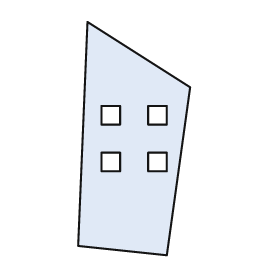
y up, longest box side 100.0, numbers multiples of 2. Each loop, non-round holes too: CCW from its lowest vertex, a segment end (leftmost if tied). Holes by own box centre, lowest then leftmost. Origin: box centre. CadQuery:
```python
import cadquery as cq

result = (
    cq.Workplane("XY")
    .moveTo(14.0, -50.0)
    .lineTo(24.0, 22.0)
    .lineTo(-20.0, 50.0)
    .lineTo(-24.0, -46.0)
    .close()
    .moveTo(-14.0, -14.0)
    .lineTo(-6.0, -14.0)
    .lineTo(-6.0, -6.0)
    .lineTo(-14.0, -6.0)
    .close()
    .moveTo(6.0, -14.0)
    .lineTo(14.0, -14.0)
    .lineTo(14.0, -6.0)
    .lineTo(6.0, -6.0)
    .close()
    .moveTo(-14.0, 6.0)
    .lineTo(-6.0, 6.0)
    .lineTo(-6.0, 14.0)
    .lineTo(-14.0, 14.0)
    .close()
    .moveTo(6.0, 6.0)
    .lineTo(14.0, 6.0)
    .lineTo(14.0, 14.0)
    .lineTo(6.0, 14.0)
    .close()
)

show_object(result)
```